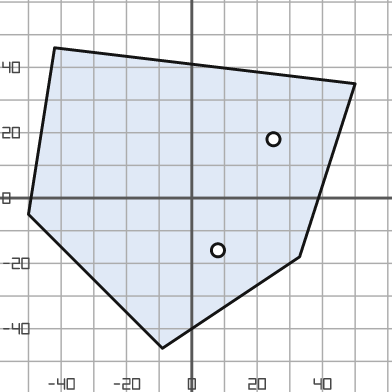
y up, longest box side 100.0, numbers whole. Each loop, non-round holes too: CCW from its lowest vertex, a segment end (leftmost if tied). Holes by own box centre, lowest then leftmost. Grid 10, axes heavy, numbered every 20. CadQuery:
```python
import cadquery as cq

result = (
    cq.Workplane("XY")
    .moveTo(-9.0, -46.0)
    .lineTo(33.0, -18.0)
    .lineTo(50.0, 35.0)
    .lineTo(-42.0, 46.0)
    .lineTo(-50.0, -5.0)
    .close()
    .moveTo(8.0, -16.0)
    .circle(2.0)
    .moveTo(25.0, 18.0)
    .circle(2.0)
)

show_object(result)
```